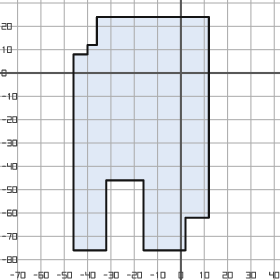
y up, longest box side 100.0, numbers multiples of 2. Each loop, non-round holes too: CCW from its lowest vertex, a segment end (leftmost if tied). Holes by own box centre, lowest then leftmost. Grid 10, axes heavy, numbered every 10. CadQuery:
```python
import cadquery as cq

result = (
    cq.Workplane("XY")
    .moveTo(-46.0, -76.0)
    .lineTo(-32.0, -76.0)
    .lineTo(-32.0, -46.0)
    .lineTo(-16.0, -46.0)
    .lineTo(-16.0, -76.0)
    .lineTo(2.0, -76.0)
    .lineTo(2.0, -62.0)
    .lineTo(12.0, -62.0)
    .lineTo(12.0, 24.0)
    .lineTo(-36.0, 24.0)
    .lineTo(-36.0, 12.0)
    .lineTo(-40.0, 12.0)
    .lineTo(-40.0, 8.0)
    .lineTo(-46.0, 8.0)
    .close()
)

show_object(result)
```